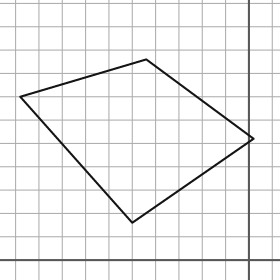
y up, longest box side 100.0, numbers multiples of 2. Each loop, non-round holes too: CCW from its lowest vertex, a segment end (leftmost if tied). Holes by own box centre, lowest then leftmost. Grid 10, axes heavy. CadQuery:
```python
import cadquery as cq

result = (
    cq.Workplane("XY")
    .moveTo(-50.0, 16.0)
    .lineTo(2.0, 52.0)
    .lineTo(-44.0, 86.0)
    .lineTo(-98.0, 70.0)
    .close()
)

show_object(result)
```